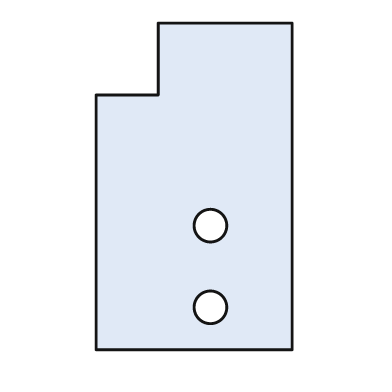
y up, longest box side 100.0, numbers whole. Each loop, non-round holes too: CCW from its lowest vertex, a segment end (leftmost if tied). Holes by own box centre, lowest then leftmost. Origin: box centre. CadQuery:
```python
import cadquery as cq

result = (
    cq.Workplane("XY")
    .moveTo(-30.0, -50.0)
    .lineTo(30.0, -50.0)
    .lineTo(30.0, 50.0)
    .lineTo(-11.0, 50.0)
    .lineTo(-11.0, 28.0)
    .lineTo(-30.0, 28.0)
    .close()
    .moveTo(5.0, -37.0)
    .circle(5.0)
    .moveTo(5.0, -12.0)
    .circle(5.0)
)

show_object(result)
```